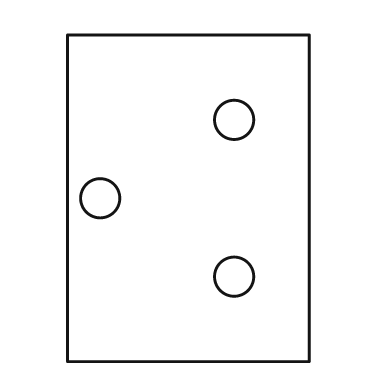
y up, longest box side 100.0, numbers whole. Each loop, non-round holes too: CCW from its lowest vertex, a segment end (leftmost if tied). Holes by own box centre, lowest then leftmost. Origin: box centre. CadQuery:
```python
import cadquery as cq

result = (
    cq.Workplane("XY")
    .moveTo(-37.0, -50.0)
    .lineTo(37.0, -50.0)
    .lineTo(37.0, 50.0)
    .lineTo(-37.0, 50.0)
    .close()
    .moveTo(14.0, -24.0)
    .circle(6.0)
    .moveTo(-27.0, 0.0)
    .circle(6.0)
    .moveTo(14.0, 24.0)
    .circle(6.0)
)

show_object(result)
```